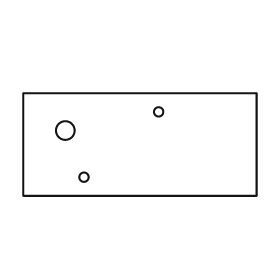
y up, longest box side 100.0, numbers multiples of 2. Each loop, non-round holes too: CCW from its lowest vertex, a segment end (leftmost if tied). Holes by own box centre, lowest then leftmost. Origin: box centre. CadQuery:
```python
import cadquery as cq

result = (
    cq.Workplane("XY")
    .moveTo(-50.0, -22.0)
    .lineTo(50.0, -22.0)
    .lineTo(50.0, 22.0)
    .lineTo(-50.0, 22.0)
    .close()
    .moveTo(-24.0, -14.0)
    .circle(2.0)
    .moveTo(-32.0, 6.0)
    .circle(4.0)
    .moveTo(8.0, 14.0)
    .circle(2.0)
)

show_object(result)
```